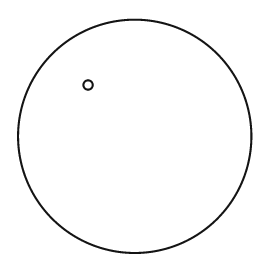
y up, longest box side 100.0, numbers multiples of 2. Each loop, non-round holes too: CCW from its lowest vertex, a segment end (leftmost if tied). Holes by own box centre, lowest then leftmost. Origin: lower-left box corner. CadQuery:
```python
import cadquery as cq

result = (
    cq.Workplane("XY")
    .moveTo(50.0, 50.0)
    .circle(50.0)
    .moveTo(30.0, 72.0)
    .circle(2.0)
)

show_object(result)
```